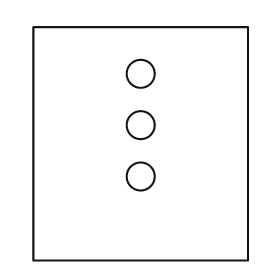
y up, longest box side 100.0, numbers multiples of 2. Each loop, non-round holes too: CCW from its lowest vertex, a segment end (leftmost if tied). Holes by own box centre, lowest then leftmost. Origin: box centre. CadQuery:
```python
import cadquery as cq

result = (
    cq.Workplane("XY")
    .moveTo(-46.0, -50.0)
    .lineTo(46.0, -50.0)
    .lineTo(46.0, 50.0)
    .lineTo(-46.0, 50.0)
    .close()
    .moveTo(0.0, -14.0)
    .circle(6.0)
    .moveTo(0.0, 8.0)
    .circle(6.0)
    .moveTo(0.0, 30.0)
    .circle(6.0)
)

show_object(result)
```